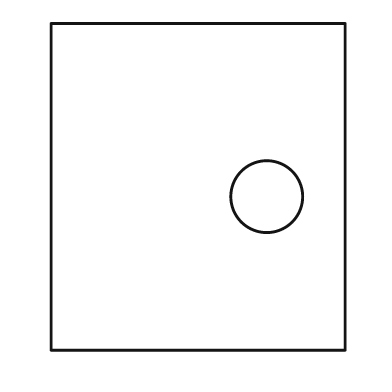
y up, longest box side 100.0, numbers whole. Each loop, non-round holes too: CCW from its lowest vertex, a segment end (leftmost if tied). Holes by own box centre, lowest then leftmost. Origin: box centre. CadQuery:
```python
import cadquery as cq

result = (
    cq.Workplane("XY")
    .moveTo(-45.0, -50.0)
    .lineTo(45.0, -50.0)
    .lineTo(45.0, 50.0)
    .lineTo(-45.0, 50.0)
    .close()
    .moveTo(21.0, -3.0)
    .circle(11.0)
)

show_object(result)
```